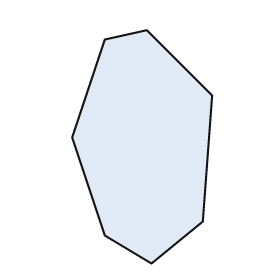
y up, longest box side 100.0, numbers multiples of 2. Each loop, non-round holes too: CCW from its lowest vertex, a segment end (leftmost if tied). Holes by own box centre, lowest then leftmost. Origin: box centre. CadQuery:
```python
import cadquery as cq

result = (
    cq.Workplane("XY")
    .moveTo(4.0, -50.0)
    .lineTo(26.0, -32.0)
    .lineTo(30.0, 22.0)
    .lineTo(2.0, 50.0)
    .lineTo(-16.0, 46.0)
    .lineTo(-30.0, 4.0)
    .lineTo(-16.0, -38.0)
    .close()
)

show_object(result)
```